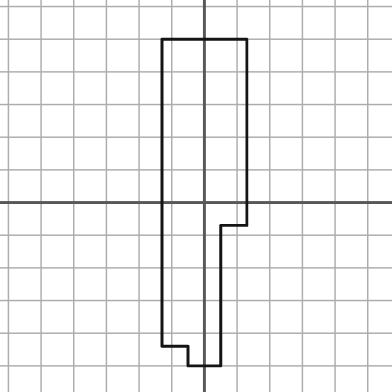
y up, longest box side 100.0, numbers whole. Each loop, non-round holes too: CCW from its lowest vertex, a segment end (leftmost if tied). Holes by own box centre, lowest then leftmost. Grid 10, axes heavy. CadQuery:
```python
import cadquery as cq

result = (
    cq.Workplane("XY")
    .moveTo(-5.0, -50.0)
    .lineTo(5.0, -50.0)
    .lineTo(5.0, -7.0)
    .lineTo(13.0, -7.0)
    .lineTo(13.0, 50.0)
    .lineTo(-13.0, 50.0)
    .lineTo(-13.0, -44.0)
    .lineTo(-5.0, -44.0)
    .close()
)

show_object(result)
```